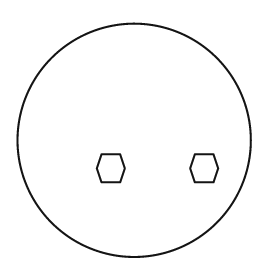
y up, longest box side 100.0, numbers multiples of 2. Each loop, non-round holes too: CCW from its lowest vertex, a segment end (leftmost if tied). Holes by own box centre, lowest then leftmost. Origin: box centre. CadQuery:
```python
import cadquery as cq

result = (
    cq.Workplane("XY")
    .moveTo(0.0, 0.0)
    .circle(50.0)
    .moveTo(-14.0, -18.0)
    .lineTo(-6.0, -18.0)
    .lineTo(-4.0, -12.0)
    .lineTo(-6.0, -6.0)
    .lineTo(-14.0, -6.0)
    .lineTo(-16.0, -12.0)
    .close()
    .moveTo(26.0, -18.0)
    .lineTo(34.0, -18.0)
    .lineTo(36.0, -12.0)
    .lineTo(34.0, -6.0)
    .lineTo(26.0, -6.0)
    .lineTo(24.0, -12.0)
    .close()
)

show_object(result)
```